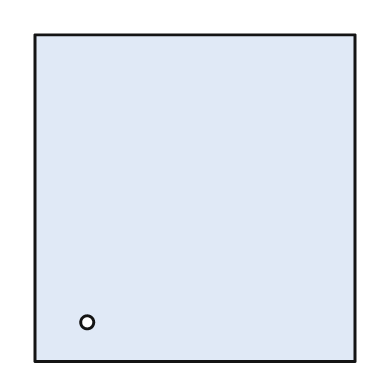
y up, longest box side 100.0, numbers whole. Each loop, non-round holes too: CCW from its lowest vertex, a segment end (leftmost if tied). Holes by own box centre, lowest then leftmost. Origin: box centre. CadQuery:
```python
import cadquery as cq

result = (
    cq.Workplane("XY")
    .moveTo(-49.0, -50.0)
    .lineTo(49.0, -50.0)
    .lineTo(49.0, 50.0)
    .lineTo(-49.0, 50.0)
    .close()
    .moveTo(-33.0, -38.0)
    .circle(2.0)
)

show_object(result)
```